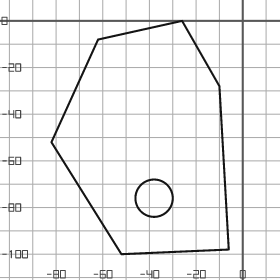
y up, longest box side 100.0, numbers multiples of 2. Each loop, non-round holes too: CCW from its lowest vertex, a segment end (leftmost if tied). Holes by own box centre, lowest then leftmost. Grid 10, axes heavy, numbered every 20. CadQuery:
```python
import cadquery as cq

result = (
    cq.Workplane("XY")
    .moveTo(-52.0, -100.0)
    .lineTo(-6.0, -98.0)
    .lineTo(-10.0, -28.0)
    .lineTo(-26.0, 0.0)
    .lineTo(-62.0, -8.0)
    .lineTo(-82.0, -52.0)
    .close()
    .moveTo(-38.0, -76.0)
    .circle(8.0)
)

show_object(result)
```